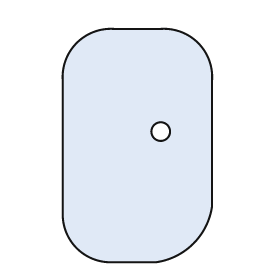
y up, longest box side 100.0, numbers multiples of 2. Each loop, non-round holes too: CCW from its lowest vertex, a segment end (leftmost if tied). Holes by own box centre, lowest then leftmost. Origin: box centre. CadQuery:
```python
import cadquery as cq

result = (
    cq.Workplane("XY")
    .moveTo(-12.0, -50.0)
    .lineTo(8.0, -50.0)
    .threePointArc((24.0, -42.0), (32.0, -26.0))
    .lineTo(32.0, 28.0)
    .threePointArc((26.0, 44.0), (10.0, 50.0))
    .lineTo(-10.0, 50.0)
    .threePointArc((-26.0, 44.0), (-32.0, 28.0))
    .lineTo(-32.0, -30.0)
    .threePointArc((-26.0, -44.0), (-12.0, -50.0))
    .close()
    .moveTo(10.0, 6.0)
    .circle(4.0)
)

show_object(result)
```